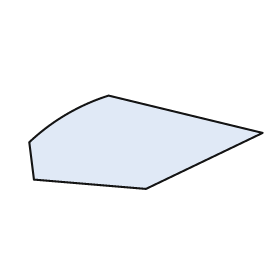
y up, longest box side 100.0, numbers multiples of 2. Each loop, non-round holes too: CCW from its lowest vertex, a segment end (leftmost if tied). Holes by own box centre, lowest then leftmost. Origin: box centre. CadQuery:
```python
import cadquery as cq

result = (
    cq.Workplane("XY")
    .moveTo(0.0, -20.0)
    .lineTo(50.0, 4.0)
    .lineTo(-16.0, 20.0)
    .threePointArc((-34.0, 12.0), (-50.0, 0.0))
    .lineTo(-48.0, -16.0)
    .close()
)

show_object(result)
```